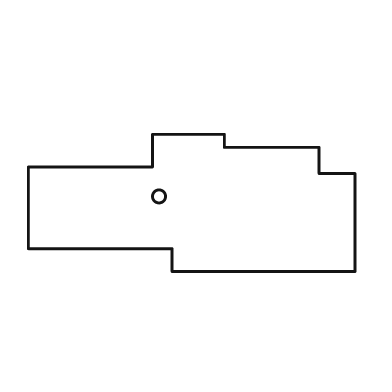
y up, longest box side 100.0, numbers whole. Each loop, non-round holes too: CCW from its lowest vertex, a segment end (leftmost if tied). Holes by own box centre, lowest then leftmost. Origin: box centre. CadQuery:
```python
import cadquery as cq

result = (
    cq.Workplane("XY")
    .moveTo(-6.0, -21.0)
    .lineTo(50.0, -21.0)
    .lineTo(50.0, 9.0)
    .lineTo(39.0, 9.0)
    .lineTo(39.0, 17.0)
    .lineTo(10.0, 17.0)
    .lineTo(10.0, 21.0)
    .lineTo(-12.0, 21.0)
    .lineTo(-12.0, 11.0)
    .lineTo(-50.0, 11.0)
    .lineTo(-50.0, -14.0)
    .lineTo(-6.0, -14.0)
    .close()
    .moveTo(-10.0, 2.0)
    .circle(2.0)
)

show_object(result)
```